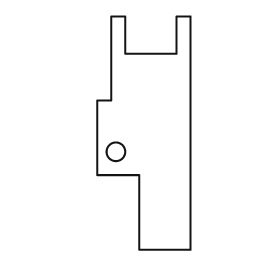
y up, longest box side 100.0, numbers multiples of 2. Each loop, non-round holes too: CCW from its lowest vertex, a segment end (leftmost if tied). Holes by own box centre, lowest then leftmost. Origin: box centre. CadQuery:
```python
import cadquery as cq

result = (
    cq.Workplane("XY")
    .moveTo(-2.0, -50.0)
    .lineTo(20.0, -50.0)
    .lineTo(20.0, 50.0)
    .lineTo(14.0, 50.0)
    .lineTo(14.0, 34.0)
    .lineTo(-8.0, 34.0)
    .lineTo(-8.0, 50.0)
    .lineTo(-14.0, 50.0)
    .lineTo(-14.0, 14.0)
    .lineTo(-20.0, 14.0)
    .lineTo(-20.0, -18.0)
    .lineTo(-2.0, -18.0)
    .close()
    .moveTo(-12.0, -8.0)
    .circle(4.0)
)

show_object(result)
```